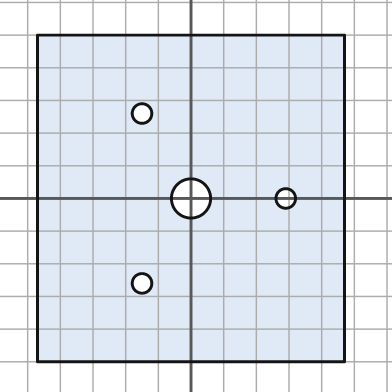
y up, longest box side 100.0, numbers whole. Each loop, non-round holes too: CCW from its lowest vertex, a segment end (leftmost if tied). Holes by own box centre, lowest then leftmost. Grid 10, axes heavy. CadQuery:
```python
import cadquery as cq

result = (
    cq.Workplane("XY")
    .moveTo(-47.0, -50.0)
    .lineTo(47.0, -50.0)
    .lineTo(47.0, 50.0)
    .lineTo(-47.0, 50.0)
    .close()
    .moveTo(-15.0, -26.0)
    .circle(3.0)
    .moveTo(0.0, 0.0)
    .circle(6.0)
    .moveTo(29.0, 0.0)
    .circle(3.0)
    .moveTo(-15.0, 26.0)
    .circle(3.0)
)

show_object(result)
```